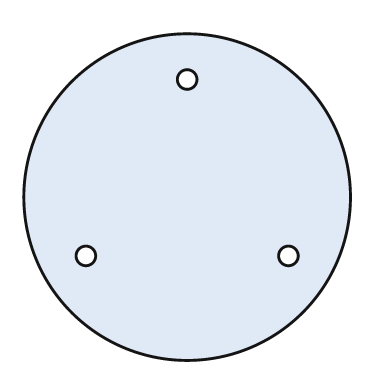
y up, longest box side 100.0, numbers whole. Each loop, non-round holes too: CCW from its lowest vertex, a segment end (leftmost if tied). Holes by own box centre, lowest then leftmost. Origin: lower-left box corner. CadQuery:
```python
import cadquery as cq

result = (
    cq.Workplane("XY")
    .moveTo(50.0, 50.0)
    .circle(50.0)
    .moveTo(19.0, 32.0)
    .circle(3.0)
    .moveTo(81.0, 32.0)
    .circle(3.0)
    .moveTo(50.0, 86.0)
    .circle(3.0)
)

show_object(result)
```